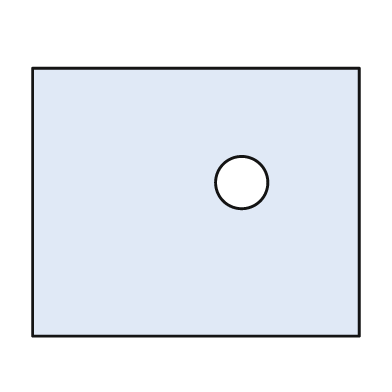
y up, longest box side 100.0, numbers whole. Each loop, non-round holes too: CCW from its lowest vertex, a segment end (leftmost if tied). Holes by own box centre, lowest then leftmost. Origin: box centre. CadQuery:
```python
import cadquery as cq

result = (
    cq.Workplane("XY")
    .moveTo(-50.0, -41.0)
    .lineTo(50.0, -41.0)
    .lineTo(50.0, 41.0)
    .lineTo(-50.0, 41.0)
    .close()
    .moveTo(14.0, 6.0)
    .circle(8.0)
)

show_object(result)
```